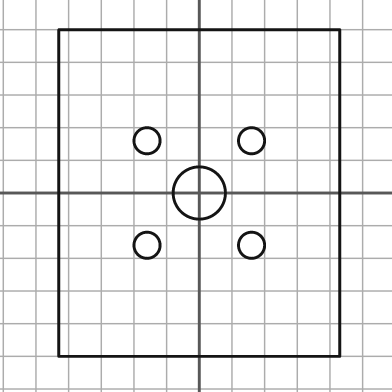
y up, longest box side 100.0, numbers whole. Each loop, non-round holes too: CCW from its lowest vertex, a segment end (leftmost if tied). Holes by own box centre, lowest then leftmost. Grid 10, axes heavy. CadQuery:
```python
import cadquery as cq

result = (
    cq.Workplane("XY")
    .moveTo(-43.0, -50.0)
    .lineTo(43.0, -50.0)
    .lineTo(43.0, 50.0)
    .lineTo(-43.0, 50.0)
    .close()
    .moveTo(-16.0, -16.0)
    .circle(4.0)
    .moveTo(16.0, -16.0)
    .circle(4.0)
    .moveTo(0.0, 0.0)
    .circle(8.0)
    .moveTo(-16.0, 16.0)
    .circle(4.0)
    .moveTo(16.0, 16.0)
    .circle(4.0)
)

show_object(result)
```